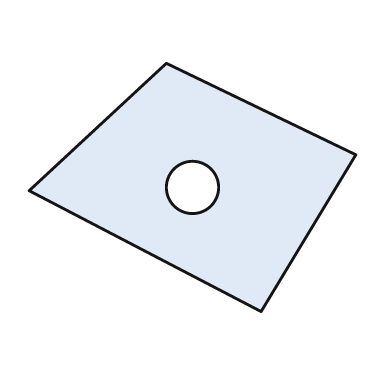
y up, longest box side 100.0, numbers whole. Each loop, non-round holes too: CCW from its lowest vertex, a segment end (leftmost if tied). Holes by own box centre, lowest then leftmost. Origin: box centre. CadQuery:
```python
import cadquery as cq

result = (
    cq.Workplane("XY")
    .moveTo(21.0, -38.0)
    .lineTo(50.0, 10.0)
    .lineTo(-8.0, 38.0)
    .lineTo(-50.0, -1.0)
    .close()
    .moveTo(0.0, 0.0)
    .circle(8.0)
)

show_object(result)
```